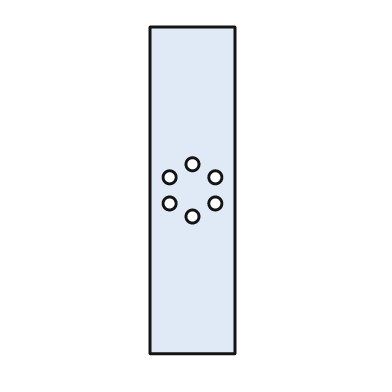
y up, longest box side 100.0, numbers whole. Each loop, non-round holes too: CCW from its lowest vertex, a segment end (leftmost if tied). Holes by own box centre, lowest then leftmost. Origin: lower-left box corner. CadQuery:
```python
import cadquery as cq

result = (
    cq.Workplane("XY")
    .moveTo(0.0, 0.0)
    .lineTo(26.0, 0.0)
    .lineTo(26.0, 100.0)
    .lineTo(0.0, 100.0)
    .close()
    .moveTo(13.0, 42.0)
    .circle(2.0)
    .moveTo(6.0, 46.0)
    .circle(2.0)
    .moveTo(20.0, 46.0)
    .circle(2.0)
    .moveTo(6.0, 54.0)
    .circle(2.0)
    .moveTo(20.0, 54.0)
    .circle(2.0)
    .moveTo(13.0, 58.0)
    .circle(2.0)
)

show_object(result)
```